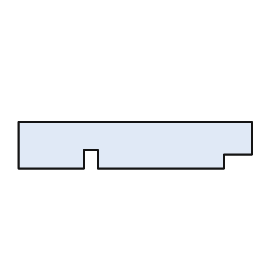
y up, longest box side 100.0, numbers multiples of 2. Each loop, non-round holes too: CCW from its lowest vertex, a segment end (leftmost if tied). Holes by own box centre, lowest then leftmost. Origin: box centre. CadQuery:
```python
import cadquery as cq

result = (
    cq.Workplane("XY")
    .moveTo(-50.0, -10.0)
    .lineTo(-22.0, -10.0)
    .lineTo(-22.0, -2.0)
    .lineTo(-16.0, -2.0)
    .lineTo(-16.0, -10.0)
    .lineTo(38.0, -10.0)
    .lineTo(38.0, -4.0)
    .lineTo(50.0, -4.0)
    .lineTo(50.0, 10.0)
    .lineTo(-50.0, 10.0)
    .close()
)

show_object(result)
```